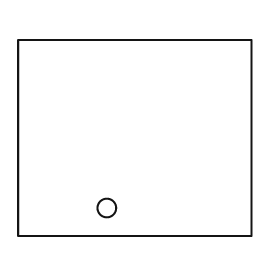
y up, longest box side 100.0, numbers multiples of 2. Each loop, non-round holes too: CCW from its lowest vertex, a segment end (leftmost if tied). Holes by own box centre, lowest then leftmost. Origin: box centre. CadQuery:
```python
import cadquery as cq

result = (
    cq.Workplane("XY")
    .moveTo(-50.0, -42.0)
    .lineTo(50.0, -42.0)
    .lineTo(50.0, 42.0)
    .lineTo(-50.0, 42.0)
    .close()
    .moveTo(-12.0, -30.0)
    .circle(4.0)
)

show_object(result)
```